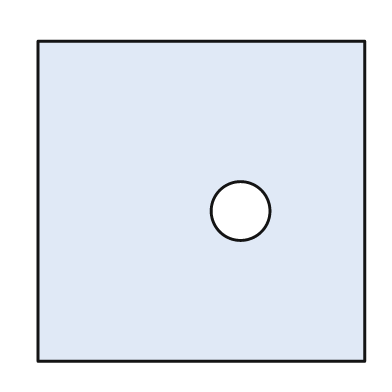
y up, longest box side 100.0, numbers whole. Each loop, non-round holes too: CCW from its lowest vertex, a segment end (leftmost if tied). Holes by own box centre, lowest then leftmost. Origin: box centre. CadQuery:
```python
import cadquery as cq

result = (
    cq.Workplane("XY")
    .moveTo(-50.0, -49.0)
    .lineTo(50.0, -49.0)
    .lineTo(50.0, 49.0)
    .lineTo(-50.0, 49.0)
    .close()
    .moveTo(12.0, -3.0)
    .circle(9.0)
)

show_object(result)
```